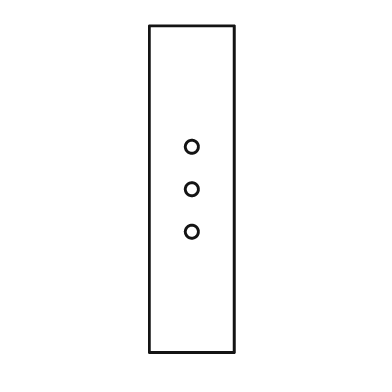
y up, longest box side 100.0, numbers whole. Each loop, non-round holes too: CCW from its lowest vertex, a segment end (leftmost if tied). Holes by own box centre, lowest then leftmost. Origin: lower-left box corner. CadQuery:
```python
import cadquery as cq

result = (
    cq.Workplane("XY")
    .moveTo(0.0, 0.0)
    .lineTo(26.0, 0.0)
    .lineTo(26.0, 100.0)
    .lineTo(0.0, 100.0)
    .close()
    .moveTo(13.0, 37.0)
    .circle(2.0)
    .moveTo(13.0, 50.0)
    .circle(2.0)
    .moveTo(13.0, 63.0)
    .circle(2.0)
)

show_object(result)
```